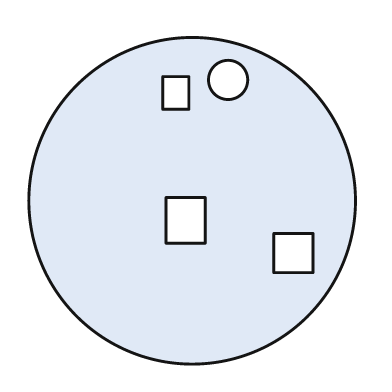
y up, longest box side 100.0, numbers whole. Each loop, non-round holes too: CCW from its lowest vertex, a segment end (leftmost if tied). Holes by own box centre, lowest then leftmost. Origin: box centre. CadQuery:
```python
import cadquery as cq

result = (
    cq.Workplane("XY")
    .moveTo(0.0, 0.0)
    .circle(50.0)
    .moveTo(25.0, -22.0)
    .lineTo(37.0, -22.0)
    .lineTo(37.0, -10.0)
    .lineTo(25.0, -10.0)
    .close()
    .moveTo(-8.0, -13.0)
    .lineTo(4.0, -13.0)
    .lineTo(4.0, 1.0)
    .lineTo(-8.0, 1.0)
    .close()
    .moveTo(-9.0, 28.0)
    .lineTo(-1.0, 28.0)
    .lineTo(-1.0, 38.0)
    .lineTo(-9.0, 38.0)
    .close()
    .moveTo(11.0, 37.0)
    .circle(6.0)
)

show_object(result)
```